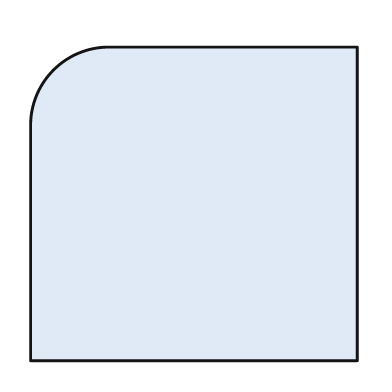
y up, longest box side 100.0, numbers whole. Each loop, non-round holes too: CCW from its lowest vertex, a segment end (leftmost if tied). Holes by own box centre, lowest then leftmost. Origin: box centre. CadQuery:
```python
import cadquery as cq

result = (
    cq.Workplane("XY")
    .moveTo(-50.0, -48.0)
    .lineTo(50.0, -48.0)
    .lineTo(50.0, 48.0)
    .lineTo(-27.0, 48.0)
    .threePointArc((-43.0, 41.0), (-50.0, 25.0))
    .close()
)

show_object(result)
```